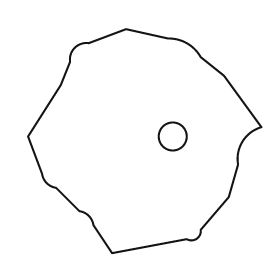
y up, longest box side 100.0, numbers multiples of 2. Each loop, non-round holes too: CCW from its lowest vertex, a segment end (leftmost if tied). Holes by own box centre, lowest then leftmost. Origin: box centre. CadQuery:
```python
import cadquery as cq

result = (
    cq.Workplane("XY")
    .moveTo(-14.0, -48.0)
    .lineTo(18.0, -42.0)
    .threePointArc((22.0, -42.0), (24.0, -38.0))
    .lineTo(36.0, -24.0)
    .lineTo(40.0, -10.0)
    .threePointArc((42.0, 0.0), (50.0, 6.0))
    .lineTo(34.0, 28.0)
    .lineTo(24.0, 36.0)
    .threePointArc((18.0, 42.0), (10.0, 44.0))
    .lineTo(-8.0, 48.0)
    .lineTo(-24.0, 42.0)
    .threePointArc((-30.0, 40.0), (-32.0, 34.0))
    .lineTo(-36.0, 24.0)
    .lineTo(-50.0, 2.0)
    .lineTo(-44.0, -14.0)
    .threePointArc((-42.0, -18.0), (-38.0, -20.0))
    .lineTo(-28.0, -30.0)
    .threePointArc((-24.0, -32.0), (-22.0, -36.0))
    .close()
    .moveTo(12.0, 2.0)
    .circle(6.0)
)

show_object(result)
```